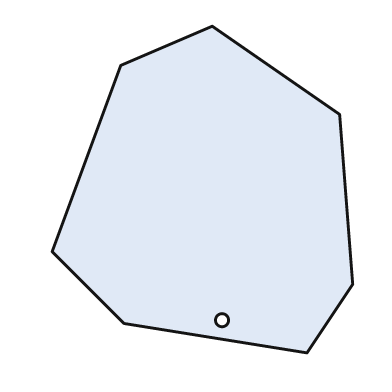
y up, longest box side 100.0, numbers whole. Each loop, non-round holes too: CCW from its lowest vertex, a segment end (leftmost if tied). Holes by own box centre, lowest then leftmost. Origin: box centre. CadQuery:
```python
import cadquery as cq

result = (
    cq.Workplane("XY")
    .moveTo(32.0, -50.0)
    .lineTo(46.0, -29.0)
    .lineTo(42.0, 23.0)
    .lineTo(3.0, 50.0)
    .lineTo(-25.0, 38.0)
    .lineTo(-46.0, -19.0)
    .lineTo(-24.0, -41.0)
    .close()
    .moveTo(6.0, -40.0)
    .circle(2.0)
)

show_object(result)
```